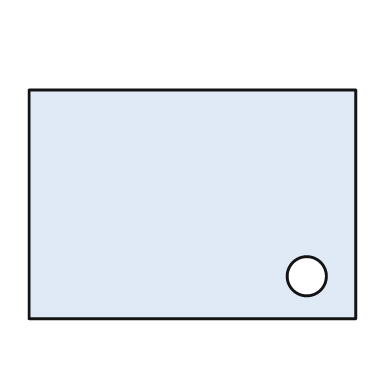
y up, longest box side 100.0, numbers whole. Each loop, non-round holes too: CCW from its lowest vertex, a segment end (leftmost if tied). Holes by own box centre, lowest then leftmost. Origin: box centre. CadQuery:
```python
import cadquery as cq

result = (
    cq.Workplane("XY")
    .moveTo(-50.0, -35.0)
    .lineTo(50.0, -35.0)
    .lineTo(50.0, 35.0)
    .lineTo(-50.0, 35.0)
    .close()
    .moveTo(35.0, -22.0)
    .circle(6.0)
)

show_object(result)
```